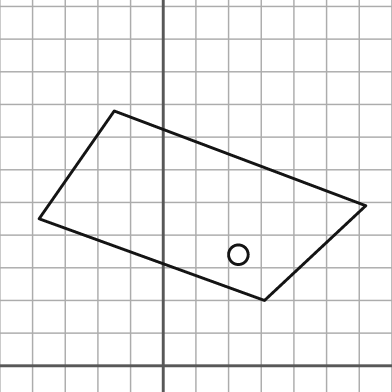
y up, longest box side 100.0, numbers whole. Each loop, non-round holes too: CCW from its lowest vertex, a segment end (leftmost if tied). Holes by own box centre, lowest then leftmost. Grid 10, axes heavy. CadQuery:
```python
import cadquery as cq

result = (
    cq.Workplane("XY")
    .moveTo(31.0, 20.0)
    .lineTo(62.0, 49.0)
    .lineTo(-15.0, 78.0)
    .lineTo(-38.0, 45.0)
    .close()
    .moveTo(23.0, 34.0)
    .circle(3.0)
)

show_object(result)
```